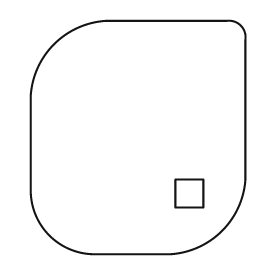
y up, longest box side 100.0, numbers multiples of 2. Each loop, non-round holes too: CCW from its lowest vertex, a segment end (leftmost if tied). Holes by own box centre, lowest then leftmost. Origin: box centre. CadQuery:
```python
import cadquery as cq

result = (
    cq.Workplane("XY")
    .moveTo(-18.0, -50.0)
    .lineTo(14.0, -50.0)
    .threePointArc((36.0, -40.0), (46.0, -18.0))
    .lineTo(46.0, 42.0)
    .threePointArc((44.0, 48.0), (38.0, 50.0))
    .lineTo(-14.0, 50.0)
    .threePointArc((-36.0, 40.0), (-46.0, 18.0))
    .lineTo(-46.0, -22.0)
    .threePointArc((-38.0, -42.0), (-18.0, -50.0))
    .close()
    .moveTo(16.0, -30.0)
    .lineTo(28.0, -30.0)
    .lineTo(28.0, -18.0)
    .lineTo(16.0, -18.0)
    .close()
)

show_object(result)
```